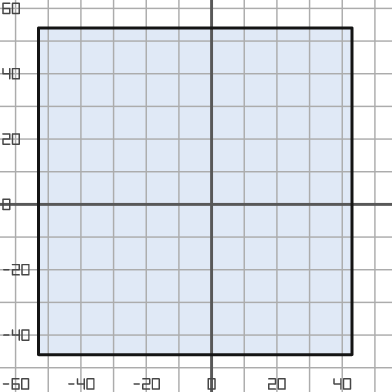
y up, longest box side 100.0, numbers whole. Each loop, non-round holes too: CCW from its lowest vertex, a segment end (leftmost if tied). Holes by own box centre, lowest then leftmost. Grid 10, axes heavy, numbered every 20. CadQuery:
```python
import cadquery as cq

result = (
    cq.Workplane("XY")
    .moveTo(-53.0, -46.0)
    .lineTo(43.0, -46.0)
    .lineTo(43.0, 54.0)
    .lineTo(-53.0, 54.0)
    .close()
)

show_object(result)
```